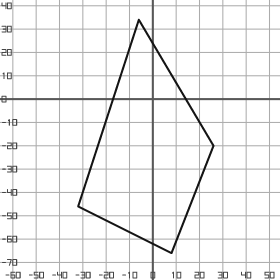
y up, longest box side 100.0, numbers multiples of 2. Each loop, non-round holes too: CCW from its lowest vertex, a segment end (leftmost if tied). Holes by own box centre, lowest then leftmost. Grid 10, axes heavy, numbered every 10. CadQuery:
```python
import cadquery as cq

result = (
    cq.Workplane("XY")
    .moveTo(8.0, -66.0)
    .lineTo(26.0, -20.0)
    .lineTo(-6.0, 34.0)
    .lineTo(-32.0, -46.0)
    .close()
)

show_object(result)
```